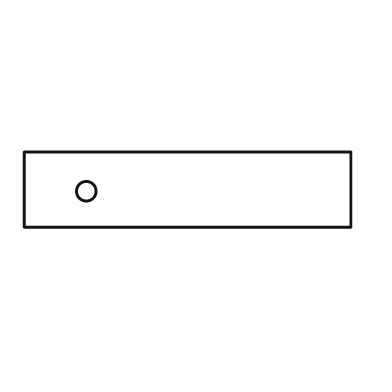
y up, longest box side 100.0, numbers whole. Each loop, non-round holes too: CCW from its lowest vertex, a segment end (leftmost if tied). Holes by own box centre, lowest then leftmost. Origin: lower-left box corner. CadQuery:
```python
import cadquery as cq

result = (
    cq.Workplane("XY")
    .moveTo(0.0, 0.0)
    .lineTo(100.0, 0.0)
    .lineTo(100.0, 23.0)
    .lineTo(0.0, 23.0)
    .close()
    .moveTo(19.0, 11.0)
    .circle(3.0)
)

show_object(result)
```